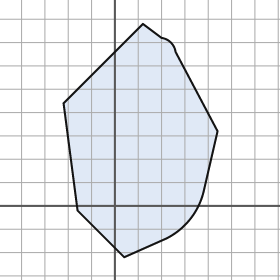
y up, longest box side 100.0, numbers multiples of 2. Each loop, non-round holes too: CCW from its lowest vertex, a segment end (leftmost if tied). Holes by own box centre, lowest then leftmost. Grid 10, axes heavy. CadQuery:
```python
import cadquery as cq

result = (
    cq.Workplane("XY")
    .moveTo(4.0, -22.0)
    .lineTo(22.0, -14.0)
    .threePointArc((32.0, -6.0), (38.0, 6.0))
    .lineTo(44.0, 32.0)
    .lineTo(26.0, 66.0)
    .threePointArc((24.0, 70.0), (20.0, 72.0))
    .lineTo(12.0, 78.0)
    .lineTo(-22.0, 44.0)
    .lineTo(-16.0, -2.0)
    .close()
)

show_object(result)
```